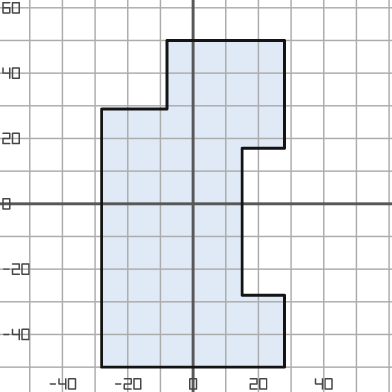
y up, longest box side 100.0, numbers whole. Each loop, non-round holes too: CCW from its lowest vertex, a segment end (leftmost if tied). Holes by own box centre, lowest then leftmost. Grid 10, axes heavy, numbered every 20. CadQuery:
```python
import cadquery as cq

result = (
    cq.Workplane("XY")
    .moveTo(-28.0, -50.0)
    .lineTo(28.0, -50.0)
    .lineTo(28.0, -28.0)
    .lineTo(15.0, -28.0)
    .lineTo(15.0, 17.0)
    .lineTo(28.0, 17.0)
    .lineTo(28.0, 50.0)
    .lineTo(-8.0, 50.0)
    .lineTo(-8.0, 29.0)
    .lineTo(-28.0, 29.0)
    .close()
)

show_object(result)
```